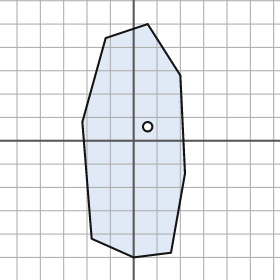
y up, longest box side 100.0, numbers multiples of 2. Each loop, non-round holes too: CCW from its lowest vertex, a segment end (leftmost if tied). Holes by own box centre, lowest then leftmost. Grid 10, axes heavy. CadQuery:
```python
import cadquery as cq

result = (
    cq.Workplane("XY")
    .moveTo(0.0, -50.0)
    .lineTo(16.0, -48.0)
    .lineTo(22.0, -14.0)
    .lineTo(20.0, 28.0)
    .lineTo(6.0, 50.0)
    .lineTo(-12.0, 44.0)
    .lineTo(-22.0, 8.0)
    .lineTo(-18.0, -42.0)
    .close()
    .moveTo(6.0, 6.0)
    .circle(2.0)
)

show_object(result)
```